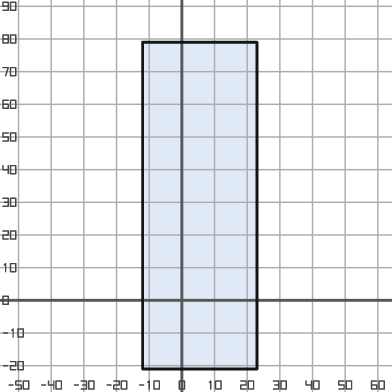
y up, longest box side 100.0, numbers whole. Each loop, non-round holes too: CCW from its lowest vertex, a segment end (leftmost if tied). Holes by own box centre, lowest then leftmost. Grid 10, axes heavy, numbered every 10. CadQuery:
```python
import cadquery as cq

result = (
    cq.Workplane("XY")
    .moveTo(-12.0, -21.0)
    .lineTo(23.0, -21.0)
    .lineTo(23.0, 79.0)
    .lineTo(-12.0, 79.0)
    .close()
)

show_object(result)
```